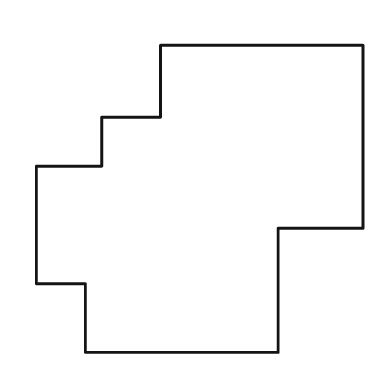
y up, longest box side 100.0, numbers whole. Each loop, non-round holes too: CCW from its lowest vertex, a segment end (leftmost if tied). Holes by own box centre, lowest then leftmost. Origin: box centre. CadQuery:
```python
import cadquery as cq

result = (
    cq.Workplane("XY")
    .moveTo(-35.0, -47.0)
    .lineTo(24.0, -47.0)
    .lineTo(24.0, -9.0)
    .lineTo(50.0, -9.0)
    .lineTo(50.0, 47.0)
    .lineTo(-12.0, 47.0)
    .lineTo(-12.0, 25.0)
    .lineTo(-30.0, 25.0)
    .lineTo(-30.0, 10.0)
    .lineTo(-50.0, 10.0)
    .lineTo(-50.0, -26.0)
    .lineTo(-35.0, -26.0)
    .close()
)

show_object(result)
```